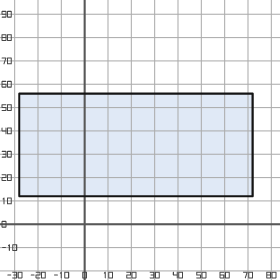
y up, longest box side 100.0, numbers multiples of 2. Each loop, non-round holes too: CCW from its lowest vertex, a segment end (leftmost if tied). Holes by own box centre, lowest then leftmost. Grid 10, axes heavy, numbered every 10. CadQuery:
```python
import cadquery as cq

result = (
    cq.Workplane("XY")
    .moveTo(-28.0, 12.0)
    .lineTo(72.0, 12.0)
    .lineTo(72.0, 56.0)
    .lineTo(-28.0, 56.0)
    .close()
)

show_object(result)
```